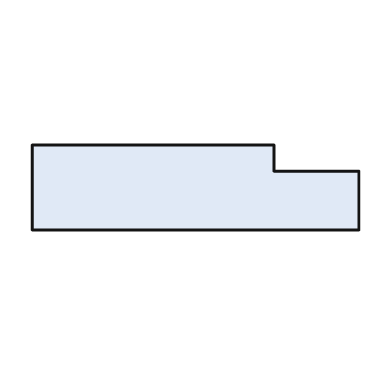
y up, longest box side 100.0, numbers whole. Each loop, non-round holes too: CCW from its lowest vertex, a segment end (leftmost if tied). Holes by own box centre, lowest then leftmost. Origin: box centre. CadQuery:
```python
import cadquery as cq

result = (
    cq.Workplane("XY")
    .moveTo(-50.0, -13.0)
    .lineTo(50.0, -13.0)
    .lineTo(50.0, 5.0)
    .lineTo(24.0, 5.0)
    .lineTo(24.0, 13.0)
    .lineTo(-50.0, 13.0)
    .close()
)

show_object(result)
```